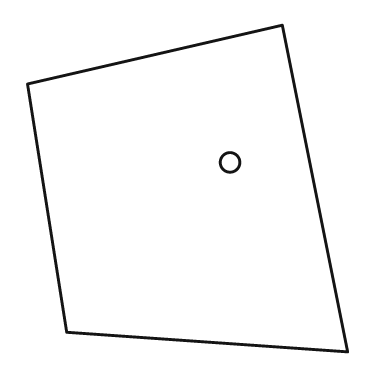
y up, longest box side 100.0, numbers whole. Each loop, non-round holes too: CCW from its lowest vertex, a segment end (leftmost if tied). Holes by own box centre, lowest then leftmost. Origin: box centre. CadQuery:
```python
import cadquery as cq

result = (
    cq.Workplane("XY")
    .moveTo(49.0, -50.0)
    .lineTo(29.0, 50.0)
    .lineTo(-49.0, 32.0)
    .lineTo(-37.0, -44.0)
    .close()
    .moveTo(13.0, 8.0)
    .circle(3.0)
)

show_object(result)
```